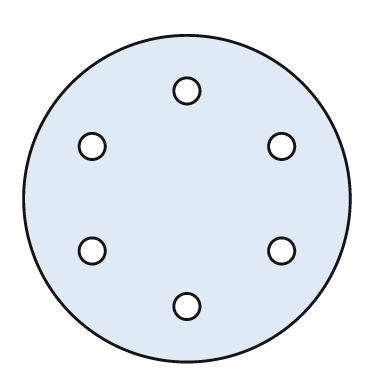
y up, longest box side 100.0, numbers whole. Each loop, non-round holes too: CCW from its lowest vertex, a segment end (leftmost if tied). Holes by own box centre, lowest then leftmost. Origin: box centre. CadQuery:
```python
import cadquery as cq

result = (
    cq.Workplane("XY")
    .moveTo(0.0, 0.0)
    .circle(50.0)
    .moveTo(0.0, -33.0)
    .circle(4.0)
    .moveTo(-29.0, -16.0)
    .circle(4.0)
    .moveTo(29.0, -16.0)
    .circle(4.0)
    .moveTo(-29.0, 16.0)
    .circle(4.0)
    .moveTo(29.0, 16.0)
    .circle(4.0)
    .moveTo(0.0, 33.0)
    .circle(4.0)
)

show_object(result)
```